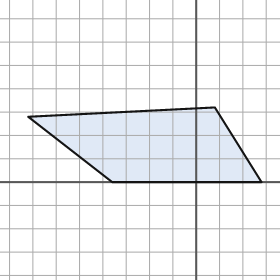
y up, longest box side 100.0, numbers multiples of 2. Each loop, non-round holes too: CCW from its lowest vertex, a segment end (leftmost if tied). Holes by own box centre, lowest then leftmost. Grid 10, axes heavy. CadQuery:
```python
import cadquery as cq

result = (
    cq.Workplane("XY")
    .moveTo(-36.0, 0.0)
    .lineTo(28.0, 0.0)
    .lineTo(8.0, 32.0)
    .lineTo(-72.0, 28.0)
    .close()
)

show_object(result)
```